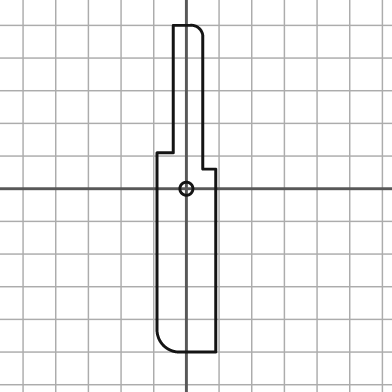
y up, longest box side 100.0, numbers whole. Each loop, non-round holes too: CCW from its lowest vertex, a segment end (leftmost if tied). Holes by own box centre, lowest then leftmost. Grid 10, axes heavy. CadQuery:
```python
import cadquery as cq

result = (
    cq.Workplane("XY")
    .moveTo(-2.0, -50.0)
    .lineTo(9.0, -50.0)
    .lineTo(9.0, 6.0)
    .lineTo(5.0, 6.0)
    .lineTo(5.0, 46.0)
    .threePointArc((4.0, 49.0), (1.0, 50.0))
    .lineTo(-4.0, 50.0)
    .lineTo(-4.0, 11.0)
    .lineTo(-9.0, 11.0)
    .lineTo(-9.0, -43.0)
    .threePointArc((-7.0, -48.0), (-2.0, -50.0))
    .close()
    .moveTo(0.0, 0.0)
    .circle(2.0)
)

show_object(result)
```